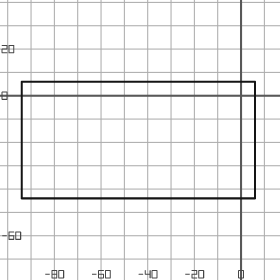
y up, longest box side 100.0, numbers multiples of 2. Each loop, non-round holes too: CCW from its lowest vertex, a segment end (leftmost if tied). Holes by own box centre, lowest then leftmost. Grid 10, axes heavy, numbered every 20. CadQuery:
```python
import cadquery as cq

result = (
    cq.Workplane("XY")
    .moveTo(-94.0, -44.0)
    .lineTo(6.0, -44.0)
    .lineTo(6.0, 6.0)
    .lineTo(-94.0, 6.0)
    .close()
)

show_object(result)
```